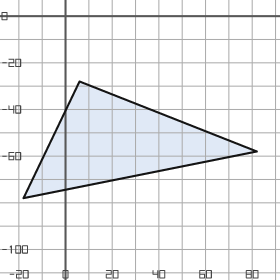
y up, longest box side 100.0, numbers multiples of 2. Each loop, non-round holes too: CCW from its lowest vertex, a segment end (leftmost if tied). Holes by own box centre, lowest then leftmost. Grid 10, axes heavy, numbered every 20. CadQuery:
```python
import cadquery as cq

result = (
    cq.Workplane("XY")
    .moveTo(-18.0, -78.0)
    .lineTo(82.0, -58.0)
    .lineTo(6.0, -28.0)
    .close()
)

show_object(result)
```